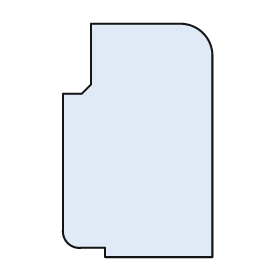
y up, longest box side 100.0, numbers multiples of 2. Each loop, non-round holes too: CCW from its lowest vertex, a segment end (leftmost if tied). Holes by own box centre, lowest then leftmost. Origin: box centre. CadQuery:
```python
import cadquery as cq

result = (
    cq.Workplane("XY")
    .moveTo(-14.0, -50.0)
    .lineTo(32.0, -50.0)
    .lineTo(32.0, 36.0)
    .threePointArc((28.0, 46.0), (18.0, 50.0))
    .lineTo(-20.0, 50.0)
    .lineTo(-20.0, 24.0)
    .lineTo(-24.0, 20.0)
    .lineTo(-32.0, 20.0)
    .lineTo(-32.0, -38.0)
    .threePointArc((-30.0, -44.0), (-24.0, -46.0))
    .lineTo(-14.0, -46.0)
    .close()
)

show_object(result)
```